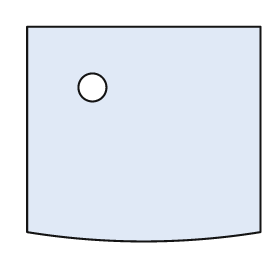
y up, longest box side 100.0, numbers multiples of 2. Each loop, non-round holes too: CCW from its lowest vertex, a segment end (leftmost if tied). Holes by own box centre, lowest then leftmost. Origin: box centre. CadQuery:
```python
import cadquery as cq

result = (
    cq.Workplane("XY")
    .moveTo(-50.0, -42.0)
    .threePointArc((0.0, -46.0), (50.0, -42.0))
    .lineTo(50.0, 46.0)
    .lineTo(-50.0, 46.0)
    .close()
    .moveTo(-22.0, 20.0)
    .circle(6.0)
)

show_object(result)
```